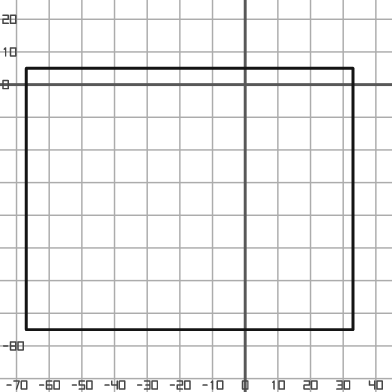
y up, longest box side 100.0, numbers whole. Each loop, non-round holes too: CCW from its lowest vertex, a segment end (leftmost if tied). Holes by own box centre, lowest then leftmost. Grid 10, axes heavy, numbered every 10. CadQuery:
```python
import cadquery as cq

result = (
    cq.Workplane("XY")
    .moveTo(-67.0, -75.0)
    .lineTo(33.0, -75.0)
    .lineTo(33.0, 5.0)
    .lineTo(-67.0, 5.0)
    .close()
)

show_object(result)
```